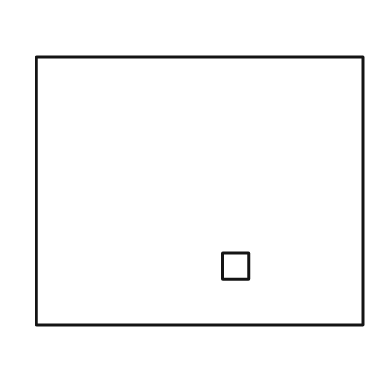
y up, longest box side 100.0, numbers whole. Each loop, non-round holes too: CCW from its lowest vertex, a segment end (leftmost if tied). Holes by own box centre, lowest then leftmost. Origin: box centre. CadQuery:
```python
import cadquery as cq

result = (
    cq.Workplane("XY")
    .moveTo(-50.0, -41.0)
    .lineTo(50.0, -41.0)
    .lineTo(50.0, 41.0)
    .lineTo(-50.0, 41.0)
    .close()
    .moveTo(7.0, -27.0)
    .lineTo(15.0, -27.0)
    .lineTo(15.0, -19.0)
    .lineTo(7.0, -19.0)
    .close()
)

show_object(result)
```